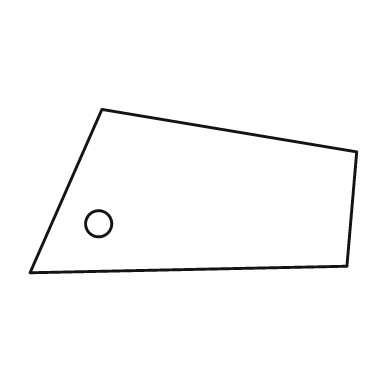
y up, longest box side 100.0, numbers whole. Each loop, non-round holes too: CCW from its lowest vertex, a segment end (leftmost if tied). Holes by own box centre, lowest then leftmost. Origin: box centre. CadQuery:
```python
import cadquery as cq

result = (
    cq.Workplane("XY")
    .moveTo(-50.0, -25.0)
    .lineTo(47.0, -23.0)
    .lineTo(50.0, 12.0)
    .lineTo(-28.0, 25.0)
    .close()
    .moveTo(-29.0, -10.0)
    .circle(4.0)
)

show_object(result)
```